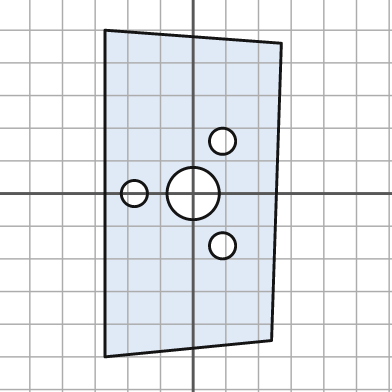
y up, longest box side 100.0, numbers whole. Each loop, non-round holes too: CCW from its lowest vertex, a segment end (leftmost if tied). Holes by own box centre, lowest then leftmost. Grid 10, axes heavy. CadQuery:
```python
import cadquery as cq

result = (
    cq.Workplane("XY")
    .moveTo(-27.0, -50.0)
    .lineTo(24.0, -45.0)
    .lineTo(27.0, 46.0)
    .lineTo(-27.0, 50.0)
    .close()
    .moveTo(9.0, -16.0)
    .circle(4.0)
    .moveTo(-18.0, 0.0)
    .circle(4.0)
    .moveTo(0.0, 0.0)
    .circle(8.0)
    .moveTo(9.0, 16.0)
    .circle(4.0)
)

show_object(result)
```